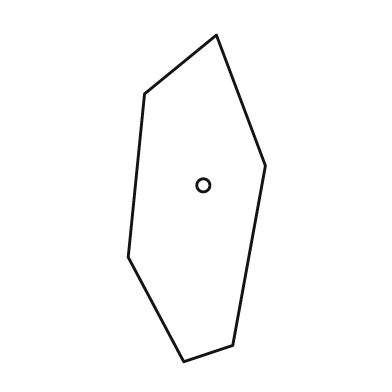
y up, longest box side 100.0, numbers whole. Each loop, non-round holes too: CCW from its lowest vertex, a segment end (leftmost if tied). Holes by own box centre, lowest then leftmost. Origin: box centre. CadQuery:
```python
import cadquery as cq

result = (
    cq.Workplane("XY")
    .moveTo(-4.0, -50.0)
    .lineTo(11.0, -45.0)
    .lineTo(21.0, 10.0)
    .lineTo(6.0, 50.0)
    .lineTo(-16.0, 32.0)
    .lineTo(-21.0, -18.0)
    .close()
    .moveTo(2.0, 4.0)
    .circle(2.0)
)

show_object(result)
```